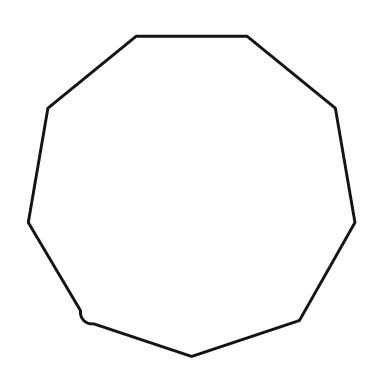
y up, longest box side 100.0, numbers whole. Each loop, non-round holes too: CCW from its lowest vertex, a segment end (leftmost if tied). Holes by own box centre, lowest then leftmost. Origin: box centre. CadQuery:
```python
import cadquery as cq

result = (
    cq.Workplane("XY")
    .moveTo(0.0, -49.0)
    .lineTo(33.0, -38.0)
    .lineTo(50.0, -8.0)
    .lineTo(44.0, 27.0)
    .lineTo(17.0, 49.0)
    .lineTo(-17.0, 49.0)
    .lineTo(-44.0, 27.0)
    .lineTo(-50.0, -8.0)
    .lineTo(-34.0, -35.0)
    .threePointArc((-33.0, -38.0), (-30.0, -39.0))
    .close()
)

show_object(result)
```